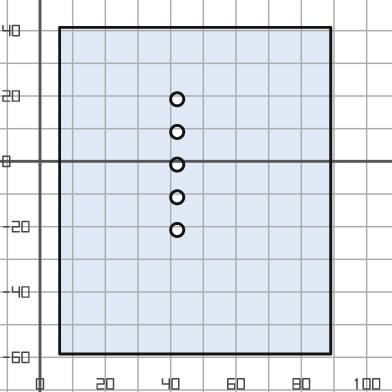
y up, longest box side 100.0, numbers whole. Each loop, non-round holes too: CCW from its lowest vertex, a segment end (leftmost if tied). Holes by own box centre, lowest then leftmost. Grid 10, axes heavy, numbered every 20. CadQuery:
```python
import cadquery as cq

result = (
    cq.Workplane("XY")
    .moveTo(6.0, -59.0)
    .lineTo(89.0, -59.0)
    .lineTo(89.0, 41.0)
    .lineTo(6.0, 41.0)
    .close()
    .moveTo(42.0, -21.0)
    .circle(2.0)
    .moveTo(42.0, -11.0)
    .circle(2.0)
    .moveTo(42.0, -1.0)
    .circle(2.0)
    .moveTo(42.0, 9.0)
    .circle(2.0)
    .moveTo(42.0, 19.0)
    .circle(2.0)
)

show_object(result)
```